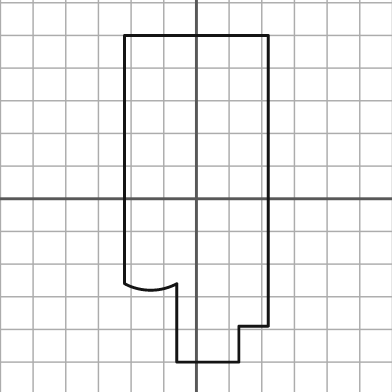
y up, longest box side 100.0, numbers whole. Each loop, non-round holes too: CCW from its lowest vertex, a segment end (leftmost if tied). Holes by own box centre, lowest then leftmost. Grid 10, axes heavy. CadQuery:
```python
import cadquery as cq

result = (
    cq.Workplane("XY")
    .moveTo(-6.0, -50.0)
    .lineTo(13.0, -50.0)
    .lineTo(13.0, -39.0)
    .lineTo(22.0, -39.0)
    .lineTo(22.0, 50.0)
    .lineTo(-22.0, 50.0)
    .lineTo(-22.0, -26.0)
    .threePointArc((-14.0, -28.0), (-6.0, -26.0))
    .close()
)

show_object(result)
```